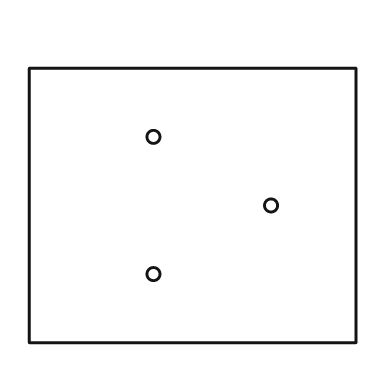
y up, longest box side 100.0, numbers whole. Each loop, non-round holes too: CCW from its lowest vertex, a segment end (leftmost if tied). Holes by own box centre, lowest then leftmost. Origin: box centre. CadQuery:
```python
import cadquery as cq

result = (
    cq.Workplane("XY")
    .moveTo(-50.0, -42.0)
    .lineTo(50.0, -42.0)
    .lineTo(50.0, 42.0)
    .lineTo(-50.0, 42.0)
    .close()
    .moveTo(-12.0, -21.0)
    .circle(2.0)
    .moveTo(24.0, 0.0)
    .circle(2.0)
    .moveTo(-12.0, 21.0)
    .circle(2.0)
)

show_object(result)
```